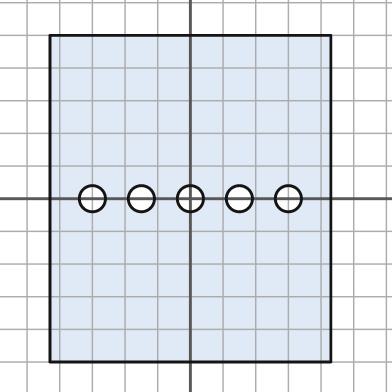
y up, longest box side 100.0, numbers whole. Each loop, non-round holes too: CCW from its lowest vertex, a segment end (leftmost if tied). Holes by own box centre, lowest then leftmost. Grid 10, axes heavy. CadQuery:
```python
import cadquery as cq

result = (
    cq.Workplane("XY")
    .moveTo(-43.0, -50.0)
    .lineTo(43.0, -50.0)
    .lineTo(43.0, 50.0)
    .lineTo(-43.0, 50.0)
    .close()
    .moveTo(-30.0, 0.0)
    .circle(4.0)
    .moveTo(-15.0, 0.0)
    .circle(4.0)
    .moveTo(0.0, 0.0)
    .circle(4.0)
    .moveTo(15.0, 0.0)
    .circle(4.0)
    .moveTo(30.0, 0.0)
    .circle(4.0)
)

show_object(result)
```